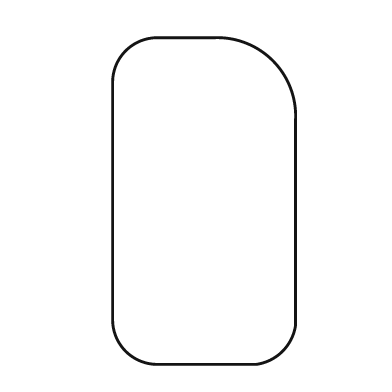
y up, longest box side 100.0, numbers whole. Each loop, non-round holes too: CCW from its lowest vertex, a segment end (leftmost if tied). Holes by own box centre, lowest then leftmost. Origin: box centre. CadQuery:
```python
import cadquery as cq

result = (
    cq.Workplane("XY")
    .moveTo(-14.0, -50.0)
    .lineTo(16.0, -50.0)
    .threePointArc((24.0, -46.0), (28.0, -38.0))
    .lineTo(28.0, 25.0)
    .threePointArc((21.0, 43.0), (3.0, 50.0))
    .lineTo(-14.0, 50.0)
    .threePointArc((-24.0, 46.0), (-28.0, 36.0))
    .lineTo(-28.0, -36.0)
    .threePointArc((-24.0, -46.0), (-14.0, -50.0))
    .close()
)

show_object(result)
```